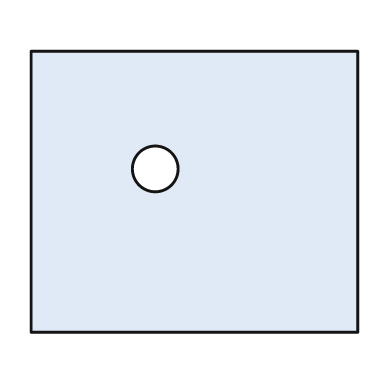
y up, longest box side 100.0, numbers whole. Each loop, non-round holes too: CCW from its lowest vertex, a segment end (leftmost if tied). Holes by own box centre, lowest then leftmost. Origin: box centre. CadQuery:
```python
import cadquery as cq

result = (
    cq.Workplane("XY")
    .moveTo(-50.0, -43.0)
    .lineTo(50.0, -43.0)
    .lineTo(50.0, 43.0)
    .lineTo(-50.0, 43.0)
    .close()
    .moveTo(-12.0, 7.0)
    .circle(7.0)
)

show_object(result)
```